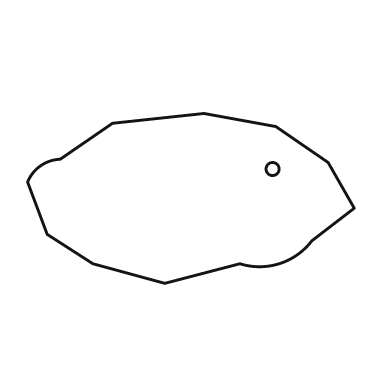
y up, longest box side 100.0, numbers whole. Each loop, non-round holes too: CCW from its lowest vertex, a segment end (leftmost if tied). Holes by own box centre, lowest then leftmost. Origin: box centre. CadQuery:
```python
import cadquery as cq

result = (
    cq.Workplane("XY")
    .moveTo(-8.0, -26.0)
    .lineTo(15.0, -20.0)
    .threePointArc((27.0, -20.0), (37.0, -13.0))
    .lineTo(50.0, -3.0)
    .lineTo(42.0, 11.0)
    .lineTo(26.0, 22.0)
    .lineTo(4.0, 26.0)
    .lineTo(-24.0, 23.0)
    .lineTo(-40.0, 12.0)
    .threePointArc((-46.0, 10.0), (-50.0, 5.0))
    .lineTo(-44.0, -11.0)
    .lineTo(-30.0, -20.0)
    .close()
    .moveTo(25.0, 9.0)
    .circle(2.0)
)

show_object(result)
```